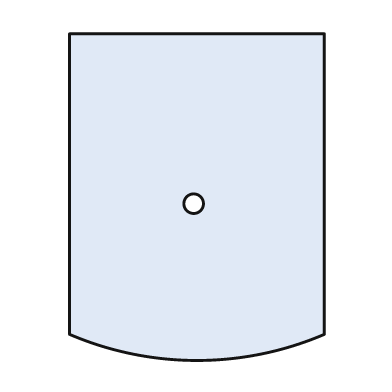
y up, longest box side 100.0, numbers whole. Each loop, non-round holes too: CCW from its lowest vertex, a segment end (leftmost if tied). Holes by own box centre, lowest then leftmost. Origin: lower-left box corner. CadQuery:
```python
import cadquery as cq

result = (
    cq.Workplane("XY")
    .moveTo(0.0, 8.0)
    .threePointArc((39.0, 0.0), (78.0, 8.0))
    .lineTo(78.0, 100.0)
    .lineTo(0.0, 100.0)
    .close()
    .moveTo(38.0, 48.0)
    .circle(3.0)
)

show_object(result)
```